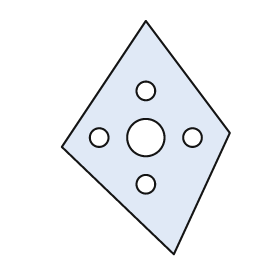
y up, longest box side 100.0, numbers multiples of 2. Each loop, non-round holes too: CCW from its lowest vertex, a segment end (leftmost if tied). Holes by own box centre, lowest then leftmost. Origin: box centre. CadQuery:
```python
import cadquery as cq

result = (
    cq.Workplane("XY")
    .moveTo(12.0, -50.0)
    .lineTo(36.0, 2.0)
    .lineTo(0.0, 50.0)
    .lineTo(-36.0, -4.0)
    .close()
    .moveTo(0.0, -20.0)
    .circle(4.0)
    .moveTo(-20.0, 0.0)
    .circle(4.0)
    .moveTo(0.0, 0.0)
    .circle(8.0)
    .moveTo(20.0, 0.0)
    .circle(4.0)
    .moveTo(0.0, 20.0)
    .circle(4.0)
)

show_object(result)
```